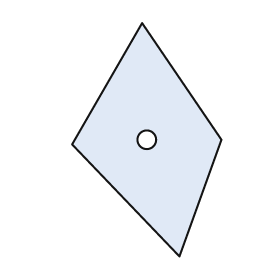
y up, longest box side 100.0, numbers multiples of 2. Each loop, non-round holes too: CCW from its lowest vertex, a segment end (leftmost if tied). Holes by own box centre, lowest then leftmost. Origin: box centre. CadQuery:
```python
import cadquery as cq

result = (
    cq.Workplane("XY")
    .moveTo(14.0, -50.0)
    .lineTo(32.0, 0.0)
    .lineTo(-2.0, 50.0)
    .lineTo(-32.0, -2.0)
    .close()
    .moveTo(0.0, 0.0)
    .circle(4.0)
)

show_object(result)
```